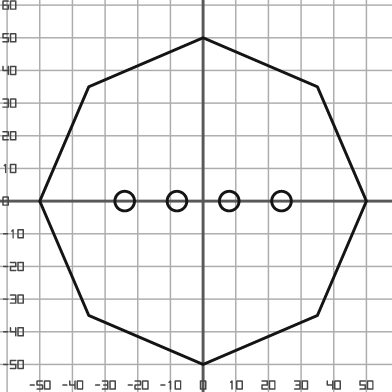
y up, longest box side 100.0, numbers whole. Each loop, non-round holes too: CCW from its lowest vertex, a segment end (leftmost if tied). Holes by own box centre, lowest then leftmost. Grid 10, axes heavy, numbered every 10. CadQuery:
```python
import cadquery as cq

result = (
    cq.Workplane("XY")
    .moveTo(0.0, -50.0)
    .lineTo(35.0, -35.0)
    .lineTo(50.0, 0.0)
    .lineTo(35.0, 35.0)
    .lineTo(0.0, 50.0)
    .lineTo(-35.0, 35.0)
    .lineTo(-50.0, 0.0)
    .lineTo(-35.0, -35.0)
    .close()
    .moveTo(-24.0, 0.0)
    .circle(3.0)
    .moveTo(-8.0, 0.0)
    .circle(3.0)
    .moveTo(8.0, 0.0)
    .circle(3.0)
    .moveTo(24.0, 0.0)
    .circle(3.0)
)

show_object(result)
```